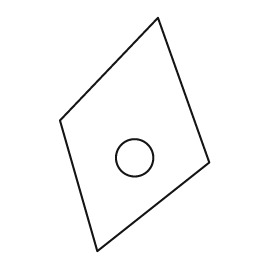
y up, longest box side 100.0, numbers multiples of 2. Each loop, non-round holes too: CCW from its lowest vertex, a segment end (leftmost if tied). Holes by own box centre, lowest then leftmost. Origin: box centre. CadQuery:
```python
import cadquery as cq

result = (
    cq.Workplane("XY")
    .moveTo(-16.0, -50.0)
    .lineTo(32.0, -12.0)
    .lineTo(10.0, 50.0)
    .lineTo(-32.0, 6.0)
    .close()
    .moveTo(0.0, -10.0)
    .circle(8.0)
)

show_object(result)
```